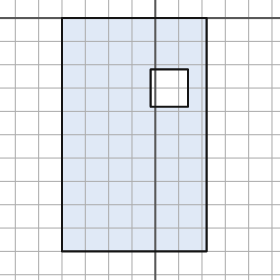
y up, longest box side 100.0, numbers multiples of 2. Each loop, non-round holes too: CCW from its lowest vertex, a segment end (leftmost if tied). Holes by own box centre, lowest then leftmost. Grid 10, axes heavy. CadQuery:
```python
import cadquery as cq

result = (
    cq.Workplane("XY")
    .moveTo(-40.0, -100.0)
    .lineTo(22.0, -100.0)
    .lineTo(22.0, 0.0)
    .lineTo(-40.0, 0.0)
    .close()
    .moveTo(-2.0, -38.0)
    .lineTo(14.0, -38.0)
    .lineTo(14.0, -22.0)
    .lineTo(-2.0, -22.0)
    .close()
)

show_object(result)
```